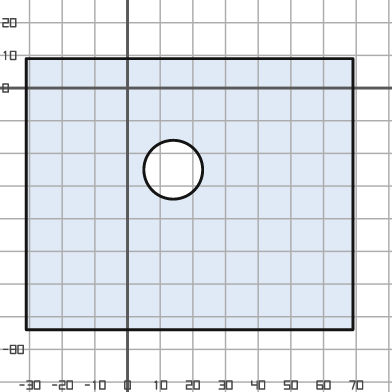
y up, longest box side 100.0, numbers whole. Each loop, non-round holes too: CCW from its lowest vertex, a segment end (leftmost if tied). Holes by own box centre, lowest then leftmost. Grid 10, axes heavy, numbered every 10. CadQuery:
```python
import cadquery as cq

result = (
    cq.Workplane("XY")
    .moveTo(-31.0, -74.0)
    .lineTo(69.0, -74.0)
    .lineTo(69.0, 9.0)
    .lineTo(-31.0, 9.0)
    .close()
    .moveTo(14.0, -25.0)
    .circle(9.0)
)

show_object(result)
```